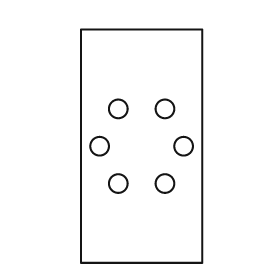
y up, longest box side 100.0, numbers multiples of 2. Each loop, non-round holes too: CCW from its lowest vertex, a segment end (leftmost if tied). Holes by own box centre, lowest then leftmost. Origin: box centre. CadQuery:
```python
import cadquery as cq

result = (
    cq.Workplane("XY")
    .moveTo(-26.0, -50.0)
    .lineTo(26.0, -50.0)
    .lineTo(26.0, 50.0)
    .lineTo(-26.0, 50.0)
    .close()
    .moveTo(-10.0, -16.0)
    .circle(4.0)
    .moveTo(10.0, -16.0)
    .circle(4.0)
    .moveTo(-18.0, 0.0)
    .circle(4.0)
    .moveTo(18.0, 0.0)
    .circle(4.0)
    .moveTo(-10.0, 16.0)
    .circle(4.0)
    .moveTo(10.0, 16.0)
    .circle(4.0)
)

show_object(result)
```